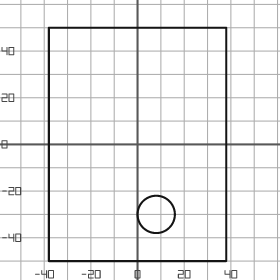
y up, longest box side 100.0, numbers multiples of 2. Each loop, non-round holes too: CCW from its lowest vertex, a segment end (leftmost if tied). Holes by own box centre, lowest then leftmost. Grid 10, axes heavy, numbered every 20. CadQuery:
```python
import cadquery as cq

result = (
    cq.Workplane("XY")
    .moveTo(-38.0, -50.0)
    .lineTo(38.0, -50.0)
    .lineTo(38.0, 50.0)
    .lineTo(-38.0, 50.0)
    .close()
    .moveTo(8.0, -30.0)
    .circle(8.0)
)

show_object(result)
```